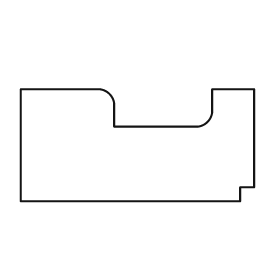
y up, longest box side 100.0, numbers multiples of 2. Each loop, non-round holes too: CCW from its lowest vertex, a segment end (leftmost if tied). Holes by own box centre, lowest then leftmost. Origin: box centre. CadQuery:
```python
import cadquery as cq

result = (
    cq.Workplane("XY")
    .moveTo(-50.0, -24.0)
    .lineTo(44.0, -24.0)
    .lineTo(44.0, -18.0)
    .lineTo(50.0, -18.0)
    .lineTo(50.0, 24.0)
    .lineTo(32.0, 24.0)
    .lineTo(32.0, 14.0)
    .threePointArc((30.0, 10.0), (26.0, 8.0))
    .lineTo(-10.0, 8.0)
    .lineTo(-10.0, 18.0)
    .threePointArc((-12.0, 22.0), (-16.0, 24.0))
    .lineTo(-50.0, 24.0)
    .close()
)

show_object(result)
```